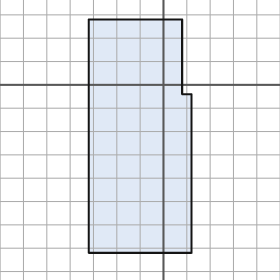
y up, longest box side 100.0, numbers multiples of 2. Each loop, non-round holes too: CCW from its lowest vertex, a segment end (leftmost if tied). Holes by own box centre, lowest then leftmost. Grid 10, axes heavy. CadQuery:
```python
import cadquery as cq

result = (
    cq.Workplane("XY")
    .moveTo(-32.0, -72.0)
    .lineTo(12.0, -72.0)
    .lineTo(12.0, -4.0)
    .lineTo(8.0, -4.0)
    .lineTo(8.0, 28.0)
    .lineTo(-32.0, 28.0)
    .close()
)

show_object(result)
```